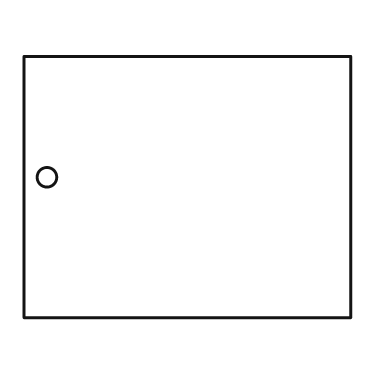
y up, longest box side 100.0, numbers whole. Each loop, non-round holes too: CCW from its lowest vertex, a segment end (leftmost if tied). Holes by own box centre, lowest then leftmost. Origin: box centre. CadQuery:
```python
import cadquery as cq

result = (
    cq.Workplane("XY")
    .moveTo(-50.0, -40.0)
    .lineTo(50.0, -40.0)
    .lineTo(50.0, 40.0)
    .lineTo(-50.0, 40.0)
    .close()
    .moveTo(-43.0, 3.0)
    .circle(3.0)
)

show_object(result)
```